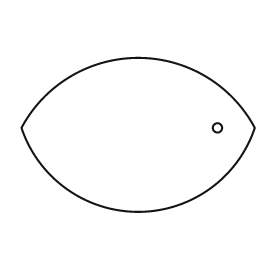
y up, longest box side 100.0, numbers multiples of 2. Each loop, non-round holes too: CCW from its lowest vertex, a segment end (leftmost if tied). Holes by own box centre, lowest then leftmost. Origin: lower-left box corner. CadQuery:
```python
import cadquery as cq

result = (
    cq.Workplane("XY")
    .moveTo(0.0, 36.0)
    .threePointArc((50.0, 0.0), (100.0, 36.0))
    .threePointArc((50.0, 66.0), (0.0, 36.0))
    .close()
    .moveTo(84.0, 36.0)
    .circle(2.0)
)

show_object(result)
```